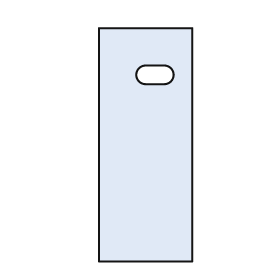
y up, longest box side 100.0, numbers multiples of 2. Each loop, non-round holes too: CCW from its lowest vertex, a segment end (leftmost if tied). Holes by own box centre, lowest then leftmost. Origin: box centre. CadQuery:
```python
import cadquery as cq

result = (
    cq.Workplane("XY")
    .moveTo(-20.0, -50.0)
    .lineTo(20.0, -50.0)
    .lineTo(20.0, 50.0)
    .lineTo(-20.0, 50.0)
    .close()
    .moveTo(0.0, 26.0)
    .lineTo(8.0, 26.0)
    .threePointArc((12.0, 30.0), (8.0, 34.0))
    .lineTo(0.0, 34.0)
    .threePointArc((-4.0, 30.0), (0.0, 26.0))
    .close()
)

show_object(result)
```